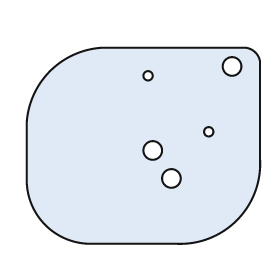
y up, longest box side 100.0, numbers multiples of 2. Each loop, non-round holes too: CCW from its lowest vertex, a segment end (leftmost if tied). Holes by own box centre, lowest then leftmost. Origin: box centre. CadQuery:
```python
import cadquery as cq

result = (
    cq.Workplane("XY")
    .moveTo(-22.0, -42.0)
    .lineTo(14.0, -42.0)
    .threePointArc((40.0, -32.0), (50.0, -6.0))
    .lineTo(50.0, 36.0)
    .threePointArc((48.0, 40.0), (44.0, 42.0))
    .lineTo(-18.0, 42.0)
    .threePointArc((-40.0, 32.0), (-50.0, 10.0))
    .lineTo(-50.0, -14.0)
    .threePointArc((-42.0, -34.0), (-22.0, -42.0))
    .close()
    .moveTo(12.0, -14.0)
    .circle(4.0)
    .moveTo(4.0, -2.0)
    .circle(4.0)
    .moveTo(28.0, 6.0)
    .circle(2.0)
    .moveTo(2.0, 30.0)
    .circle(2.0)
    .moveTo(38.0, 34.0)
    .circle(4.0)
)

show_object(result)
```